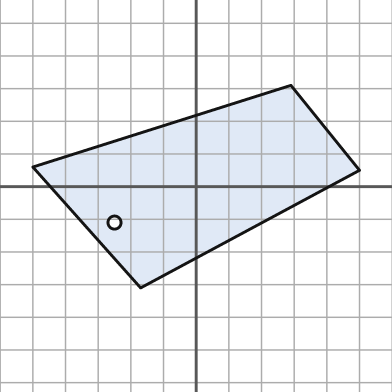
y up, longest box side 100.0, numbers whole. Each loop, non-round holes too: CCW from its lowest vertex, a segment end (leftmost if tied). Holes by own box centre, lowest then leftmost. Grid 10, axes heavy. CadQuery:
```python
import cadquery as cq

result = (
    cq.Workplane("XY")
    .moveTo(-17.0, -31.0)
    .lineTo(50.0, 5.0)
    .lineTo(29.0, 31.0)
    .lineTo(-50.0, 6.0)
    .close()
    .moveTo(-25.0, -11.0)
    .circle(2.0)
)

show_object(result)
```